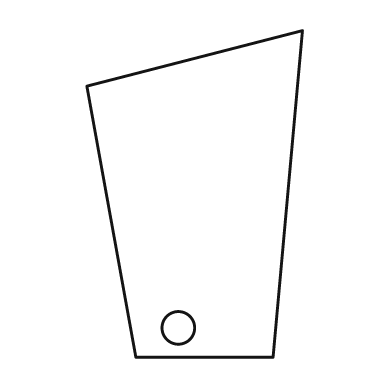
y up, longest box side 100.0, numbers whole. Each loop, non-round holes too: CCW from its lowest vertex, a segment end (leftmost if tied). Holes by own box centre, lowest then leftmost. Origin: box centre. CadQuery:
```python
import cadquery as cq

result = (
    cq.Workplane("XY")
    .moveTo(-18.0, -50.0)
    .lineTo(24.0, -50.0)
    .lineTo(33.0, 50.0)
    .lineTo(-33.0, 33.0)
    .close()
    .moveTo(-5.0, -41.0)
    .circle(5.0)
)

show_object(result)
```